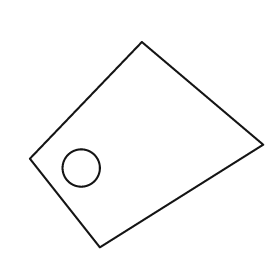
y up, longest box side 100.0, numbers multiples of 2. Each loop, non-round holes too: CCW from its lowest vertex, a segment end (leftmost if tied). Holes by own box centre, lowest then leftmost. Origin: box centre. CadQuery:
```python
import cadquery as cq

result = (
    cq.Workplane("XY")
    .moveTo(-20.0, -44.0)
    .lineTo(50.0, 0.0)
    .lineTo(-2.0, 44.0)
    .lineTo(-50.0, -6.0)
    .close()
    .moveTo(-28.0, -10.0)
    .circle(8.0)
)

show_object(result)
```